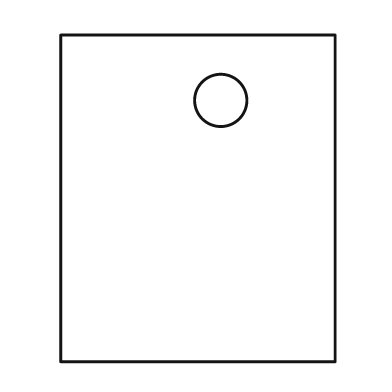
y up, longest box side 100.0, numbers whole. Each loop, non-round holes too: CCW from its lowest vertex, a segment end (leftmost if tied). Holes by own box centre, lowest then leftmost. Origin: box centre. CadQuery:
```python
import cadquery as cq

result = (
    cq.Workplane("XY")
    .moveTo(-42.0, -50.0)
    .lineTo(42.0, -50.0)
    .lineTo(42.0, 50.0)
    .lineTo(-42.0, 50.0)
    .close()
    .moveTo(7.0, 30.0)
    .circle(8.0)
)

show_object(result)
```